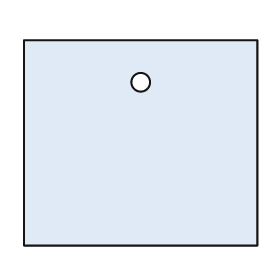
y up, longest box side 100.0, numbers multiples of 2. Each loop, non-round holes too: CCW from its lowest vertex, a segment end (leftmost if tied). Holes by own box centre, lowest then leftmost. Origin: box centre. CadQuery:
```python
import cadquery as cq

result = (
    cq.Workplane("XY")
    .moveTo(-50.0, -44.0)
    .lineTo(50.0, -44.0)
    .lineTo(50.0, 44.0)
    .lineTo(-50.0, 44.0)
    .close()
    .moveTo(0.0, 26.0)
    .circle(4.0)
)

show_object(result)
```